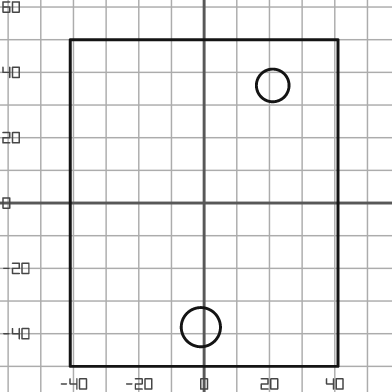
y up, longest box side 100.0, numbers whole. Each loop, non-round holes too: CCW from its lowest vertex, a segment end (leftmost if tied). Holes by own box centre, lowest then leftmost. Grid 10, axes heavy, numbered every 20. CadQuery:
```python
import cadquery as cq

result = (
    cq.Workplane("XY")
    .moveTo(-41.0, -50.0)
    .lineTo(41.0, -50.0)
    .lineTo(41.0, 50.0)
    .lineTo(-41.0, 50.0)
    .close()
    .moveTo(-1.0, -38.0)
    .circle(6.0)
    .moveTo(21.0, 36.0)
    .circle(5.0)
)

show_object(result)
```